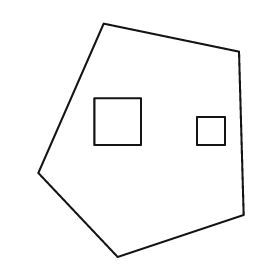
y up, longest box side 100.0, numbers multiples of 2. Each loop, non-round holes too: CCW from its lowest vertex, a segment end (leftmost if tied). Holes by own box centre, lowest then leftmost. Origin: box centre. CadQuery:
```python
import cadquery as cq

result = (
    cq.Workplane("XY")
    .moveTo(-10.0, -50.0)
    .lineTo(44.0, -32.0)
    .lineTo(42.0, 38.0)
    .lineTo(-16.0, 50.0)
    .lineTo(-44.0, -14.0)
    .close()
    .moveTo(24.0, -2.0)
    .lineTo(36.0, -2.0)
    .lineTo(36.0, 10.0)
    .lineTo(24.0, 10.0)
    .close()
    .moveTo(-20.0, -2.0)
    .lineTo(0.0, -2.0)
    .lineTo(0.0, 18.0)
    .lineTo(-20.0, 18.0)
    .close()
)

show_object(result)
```